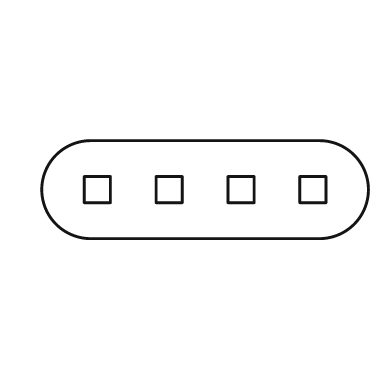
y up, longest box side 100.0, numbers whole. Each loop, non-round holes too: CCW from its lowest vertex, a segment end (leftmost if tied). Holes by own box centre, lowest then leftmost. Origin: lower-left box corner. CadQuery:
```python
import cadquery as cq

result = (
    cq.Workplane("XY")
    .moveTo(15.0, 0.0)
    .lineTo(85.0, 0.0)
    .threePointArc((100.0, 15.0), (85.0, 30.0))
    .lineTo(15.0, 30.0)
    .threePointArc((0.0, 15.0), (15.0, 0.0))
    .close()
    .moveTo(13.0, 11.0)
    .lineTo(21.0, 11.0)
    .lineTo(21.0, 19.0)
    .lineTo(13.0, 19.0)
    .close()
    .moveTo(35.0, 11.0)
    .lineTo(43.0, 11.0)
    .lineTo(43.0, 19.0)
    .lineTo(35.0, 19.0)
    .close()
    .moveTo(57.0, 11.0)
    .lineTo(65.0, 11.0)
    .lineTo(65.0, 19.0)
    .lineTo(57.0, 19.0)
    .close()
    .moveTo(79.0, 11.0)
    .lineTo(87.0, 11.0)
    .lineTo(87.0, 19.0)
    .lineTo(79.0, 19.0)
    .close()
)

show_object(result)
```